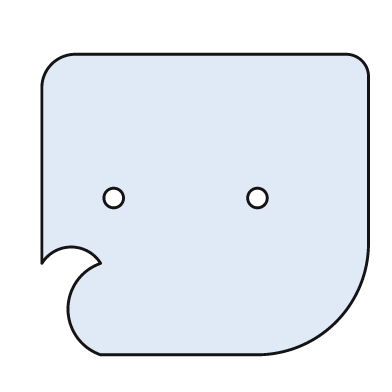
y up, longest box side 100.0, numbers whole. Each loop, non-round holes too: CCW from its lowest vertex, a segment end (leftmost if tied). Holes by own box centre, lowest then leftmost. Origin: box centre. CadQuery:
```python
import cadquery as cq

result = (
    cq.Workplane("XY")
    .moveTo(-32.0, -46.0)
    .lineTo(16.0, -46.0)
    .threePointArc((40.0, -36.0), (50.0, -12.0))
    .lineTo(50.0, 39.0)
    .threePointArc((48.0, 44.0), (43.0, 46.0))
    .lineTo(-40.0, 46.0)
    .threePointArc((-47.0, 43.0), (-50.0, 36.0))
    .lineTo(-50.0, -18.0)
    .threePointArc((-41.0, -13.0), (-32.0, -18.0))
    .threePointArc((-42.0, -32.0), (-32.0, -46.0))
    .close()
    .moveTo(-28.0, 2.0)
    .circle(3.0)
    .moveTo(16.0, 2.0)
    .circle(3.0)
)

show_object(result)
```